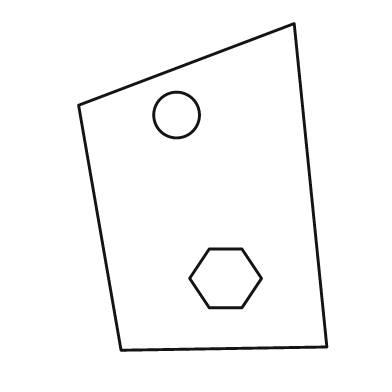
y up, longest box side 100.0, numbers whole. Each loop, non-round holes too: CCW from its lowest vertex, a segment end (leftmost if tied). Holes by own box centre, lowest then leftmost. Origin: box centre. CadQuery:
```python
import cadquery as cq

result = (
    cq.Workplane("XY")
    .moveTo(-25.0, -50.0)
    .lineTo(38.0, -49.0)
    .lineTo(28.0, 50.0)
    .lineTo(-38.0, 25.0)
    .close()
    .moveTo(2.0, -37.0)
    .lineTo(12.0, -37.0)
    .lineTo(18.0, -28.0)
    .lineTo(12.0, -19.0)
    .lineTo(2.0, -19.0)
    .lineTo(-4.0, -28.0)
    .close()
    .moveTo(-8.0, 22.0)
    .circle(7.0)
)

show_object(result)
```